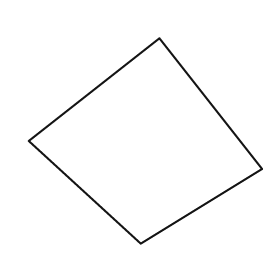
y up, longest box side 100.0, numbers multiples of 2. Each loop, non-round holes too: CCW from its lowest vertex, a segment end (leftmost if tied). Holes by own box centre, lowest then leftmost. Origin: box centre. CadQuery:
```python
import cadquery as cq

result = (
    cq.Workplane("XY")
    .moveTo(-2.0, -44.0)
    .lineTo(50.0, -12.0)
    .lineTo(6.0, 44.0)
    .lineTo(-50.0, 0.0)
    .close()
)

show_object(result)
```